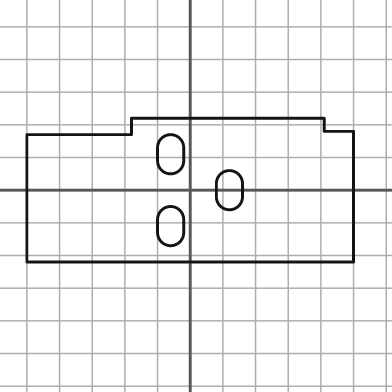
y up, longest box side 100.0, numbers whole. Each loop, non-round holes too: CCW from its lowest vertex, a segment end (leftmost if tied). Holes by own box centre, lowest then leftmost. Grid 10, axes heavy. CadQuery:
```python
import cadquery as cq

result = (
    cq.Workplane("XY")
    .moveTo(-50.0, -22.0)
    .lineTo(50.0, -22.0)
    .lineTo(50.0, 18.0)
    .lineTo(41.0, 18.0)
    .lineTo(41.0, 22.0)
    .lineTo(-18.0, 22.0)
    .lineTo(-18.0, 17.0)
    .lineTo(-50.0, 17.0)
    .close()
    .moveTo(-10.0, -13.0)
    .threePointArc((-6.0, -17.0), (-2.0, -13.0))
    .lineTo(-2.0, -9.0)
    .threePointArc((-6.0, -5.0), (-10.0, -9.0))
    .close()
    .moveTo(8.0, -2.0)
    .threePointArc((12.0, -6.0), (16.0, -2.0))
    .lineTo(16.0, 2.0)
    .threePointArc((12.0, 6.0), (8.0, 2.0))
    .close()
    .moveTo(-10.0, 9.0)
    .threePointArc((-6.0, 5.0), (-2.0, 9.0))
    .lineTo(-2.0, 13.0)
    .threePointArc((-6.0, 17.0), (-10.0, 13.0))
    .close()
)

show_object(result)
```